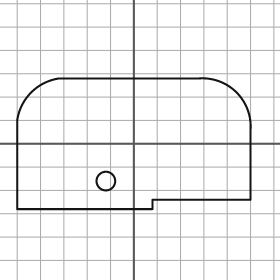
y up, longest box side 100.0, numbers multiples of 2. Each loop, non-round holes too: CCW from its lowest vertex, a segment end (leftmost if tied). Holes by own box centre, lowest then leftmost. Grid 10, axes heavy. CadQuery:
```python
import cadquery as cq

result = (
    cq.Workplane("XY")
    .moveTo(-50.0, -28.0)
    .lineTo(8.0, -28.0)
    .lineTo(8.0, -24.0)
    .lineTo(50.0, -24.0)
    .lineTo(50.0, 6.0)
    .threePointArc((44.0, 22.0), (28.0, 28.0))
    .lineTo(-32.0, 28.0)
    .threePointArc((-44.0, 22.0), (-50.0, 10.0))
    .close()
    .moveTo(-12.0, -16.0)
    .circle(4.0)
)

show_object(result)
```